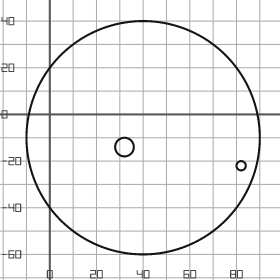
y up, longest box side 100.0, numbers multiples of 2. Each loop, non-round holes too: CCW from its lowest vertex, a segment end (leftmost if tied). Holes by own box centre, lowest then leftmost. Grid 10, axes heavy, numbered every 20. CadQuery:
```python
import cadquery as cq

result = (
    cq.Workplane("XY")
    .moveTo(40.0, -10.0)
    .circle(50.0)
    .moveTo(82.0, -22.0)
    .circle(2.0)
    .moveTo(32.0, -14.0)
    .circle(4.0)
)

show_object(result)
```